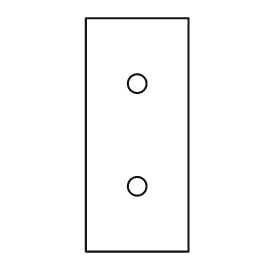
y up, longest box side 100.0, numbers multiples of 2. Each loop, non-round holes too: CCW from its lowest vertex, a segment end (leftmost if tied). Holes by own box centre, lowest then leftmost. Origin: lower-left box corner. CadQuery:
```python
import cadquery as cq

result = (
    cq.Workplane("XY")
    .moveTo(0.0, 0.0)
    .lineTo(44.0, 0.0)
    .lineTo(44.0, 100.0)
    .lineTo(0.0, 100.0)
    .close()
    .moveTo(22.0, 28.0)
    .circle(4.0)
    .moveTo(22.0, 72.0)
    .circle(4.0)
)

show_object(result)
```